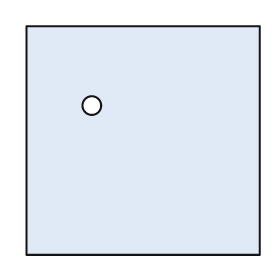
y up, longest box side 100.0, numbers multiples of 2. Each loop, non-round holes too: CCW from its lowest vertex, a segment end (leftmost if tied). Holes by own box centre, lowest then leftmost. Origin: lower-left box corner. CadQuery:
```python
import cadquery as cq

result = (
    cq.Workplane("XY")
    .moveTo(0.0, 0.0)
    .lineTo(100.0, 0.0)
    .lineTo(100.0, 98.0)
    .lineTo(0.0, 98.0)
    .close()
    .moveTo(28.0, 64.0)
    .circle(4.0)
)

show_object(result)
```